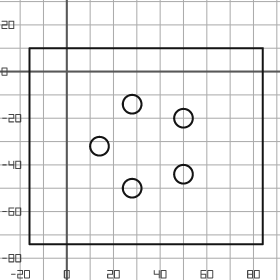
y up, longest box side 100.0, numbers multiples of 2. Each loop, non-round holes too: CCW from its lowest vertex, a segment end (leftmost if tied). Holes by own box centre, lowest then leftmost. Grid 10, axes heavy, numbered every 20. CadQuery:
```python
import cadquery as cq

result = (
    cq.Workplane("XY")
    .moveTo(-16.0, -74.0)
    .lineTo(84.0, -74.0)
    .lineTo(84.0, 10.0)
    .lineTo(-16.0, 10.0)
    .close()
    .moveTo(28.0, -50.0)
    .circle(4.0)
    .moveTo(50.0, -44.0)
    .circle(4.0)
    .moveTo(14.0, -32.0)
    .circle(4.0)
    .moveTo(50.0, -20.0)
    .circle(4.0)
    .moveTo(28.0, -14.0)
    .circle(4.0)
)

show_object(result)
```